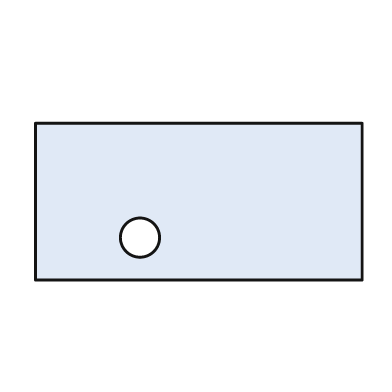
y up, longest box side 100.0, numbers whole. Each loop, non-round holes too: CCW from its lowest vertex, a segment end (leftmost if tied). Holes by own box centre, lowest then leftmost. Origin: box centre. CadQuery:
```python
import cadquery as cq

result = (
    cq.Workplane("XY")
    .moveTo(-50.0, -24.0)
    .lineTo(50.0, -24.0)
    .lineTo(50.0, 24.0)
    .lineTo(-50.0, 24.0)
    .close()
    .moveTo(-18.0, -11.0)
    .circle(6.0)
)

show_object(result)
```